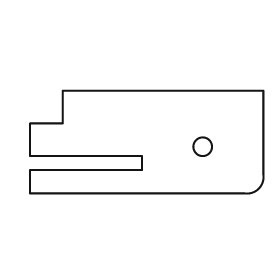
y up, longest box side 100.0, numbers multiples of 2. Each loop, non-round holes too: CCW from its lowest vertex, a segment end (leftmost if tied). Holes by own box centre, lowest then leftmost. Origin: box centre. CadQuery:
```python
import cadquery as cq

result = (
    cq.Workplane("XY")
    .moveTo(-50.0, -22.0)
    .lineTo(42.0, -22.0)
    .threePointArc((48.0, -20.0), (50.0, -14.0))
    .lineTo(50.0, 22.0)
    .lineTo(-36.0, 22.0)
    .lineTo(-36.0, 8.0)
    .lineTo(-50.0, 8.0)
    .lineTo(-50.0, -6.0)
    .lineTo(-2.0, -6.0)
    .lineTo(-2.0, -12.0)
    .lineTo(-50.0, -12.0)
    .close()
    .moveTo(24.0, -2.0)
    .circle(4.0)
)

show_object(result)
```